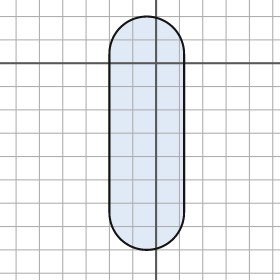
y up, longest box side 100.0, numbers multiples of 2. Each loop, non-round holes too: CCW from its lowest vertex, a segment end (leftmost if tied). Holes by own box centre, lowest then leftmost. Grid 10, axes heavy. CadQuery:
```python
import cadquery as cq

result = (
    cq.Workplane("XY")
    .moveTo(-20.0, -64.0)
    .threePointArc((-4.0, -80.0), (12.0, -64.0))
    .lineTo(12.0, 4.0)
    .threePointArc((-4.0, 20.0), (-20.0, 4.0))
    .close()
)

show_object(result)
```